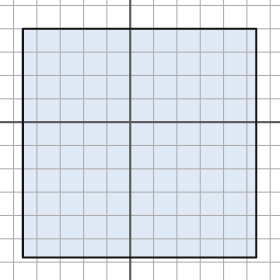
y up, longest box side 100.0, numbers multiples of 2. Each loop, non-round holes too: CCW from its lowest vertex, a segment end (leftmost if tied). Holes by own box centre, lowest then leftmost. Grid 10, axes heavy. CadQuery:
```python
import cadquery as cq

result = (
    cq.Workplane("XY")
    .moveTo(-46.0, -58.0)
    .lineTo(54.0, -58.0)
    .lineTo(54.0, 40.0)
    .lineTo(-46.0, 40.0)
    .close()
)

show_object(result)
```